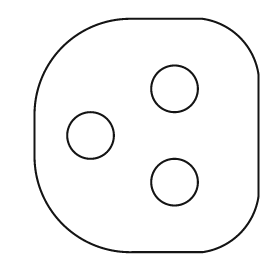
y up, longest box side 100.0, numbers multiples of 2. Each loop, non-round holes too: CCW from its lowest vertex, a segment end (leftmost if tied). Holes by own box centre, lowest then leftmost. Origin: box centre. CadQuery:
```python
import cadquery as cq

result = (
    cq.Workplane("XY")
    .moveTo(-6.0, -50.0)
    .lineTo(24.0, -50.0)
    .threePointArc((40.0, -42.0), (48.0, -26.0))
    .lineTo(48.0, 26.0)
    .threePointArc((40.0, 42.0), (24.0, 50.0))
    .lineTo(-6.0, 50.0)
    .threePointArc((-36.0, 38.0), (-48.0, 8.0))
    .lineTo(-48.0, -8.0)
    .threePointArc((-36.0, -38.0), (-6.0, -50.0))
    .close()
    .moveTo(12.0, -20.0)
    .circle(10.0)
    .moveTo(-24.0, 0.0)
    .circle(10.0)
    .moveTo(12.0, 20.0)
    .circle(10.0)
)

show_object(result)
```